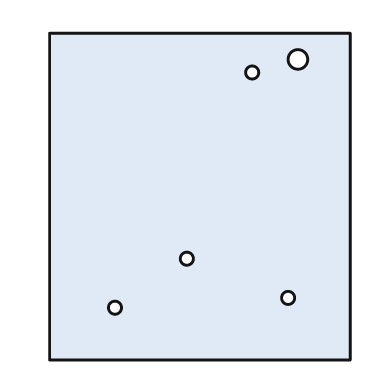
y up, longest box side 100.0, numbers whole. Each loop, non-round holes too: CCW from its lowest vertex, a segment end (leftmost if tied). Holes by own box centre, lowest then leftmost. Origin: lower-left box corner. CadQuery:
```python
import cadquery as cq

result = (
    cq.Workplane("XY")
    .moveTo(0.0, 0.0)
    .lineTo(92.0, 0.0)
    .lineTo(92.0, 100.0)
    .lineTo(0.0, 100.0)
    .close()
    .moveTo(20.0, 16.0)
    .circle(2.0)
    .moveTo(73.0, 19.0)
    .circle(2.0)
    .moveTo(42.0, 31.0)
    .circle(2.0)
    .moveTo(62.0, 88.0)
    .circle(2.0)
    .moveTo(76.0, 92.0)
    .circle(3.0)
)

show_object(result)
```